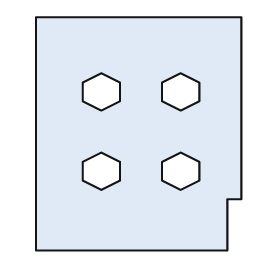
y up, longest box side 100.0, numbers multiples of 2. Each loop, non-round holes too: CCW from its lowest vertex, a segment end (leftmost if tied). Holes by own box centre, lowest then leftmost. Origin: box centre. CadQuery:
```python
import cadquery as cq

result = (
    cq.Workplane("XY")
    .moveTo(-44.0, -50.0)
    .lineTo(38.0, -50.0)
    .lineTo(38.0, -28.0)
    .lineTo(44.0, -28.0)
    .lineTo(44.0, 50.0)
    .lineTo(-44.0, 50.0)
    .close()
    .moveTo(-16.0, -24.0)
    .lineTo(-8.0, -20.0)
    .lineTo(-8.0, -12.0)
    .lineTo(-16.0, -8.0)
    .lineTo(-24.0, -12.0)
    .lineTo(-24.0, -20.0)
    .close()
    .moveTo(18.0, -24.0)
    .lineTo(26.0, -20.0)
    .lineTo(26.0, -12.0)
    .lineTo(18.0, -8.0)
    .lineTo(10.0, -12.0)
    .lineTo(10.0, -20.0)
    .close()
    .moveTo(-16.0, 10.0)
    .lineTo(-8.0, 14.0)
    .lineTo(-8.0, 22.0)
    .lineTo(-16.0, 26.0)
    .lineTo(-24.0, 22.0)
    .lineTo(-24.0, 14.0)
    .close()
    .moveTo(18.0, 10.0)
    .lineTo(26.0, 14.0)
    .lineTo(26.0, 22.0)
    .lineTo(18.0, 26.0)
    .lineTo(10.0, 22.0)
    .lineTo(10.0, 14.0)
    .close()
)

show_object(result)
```